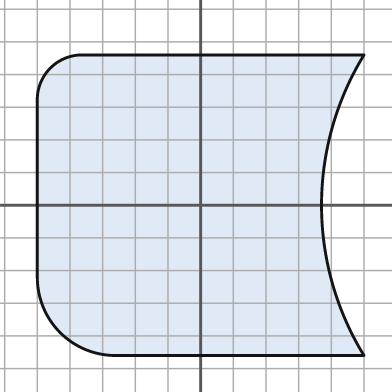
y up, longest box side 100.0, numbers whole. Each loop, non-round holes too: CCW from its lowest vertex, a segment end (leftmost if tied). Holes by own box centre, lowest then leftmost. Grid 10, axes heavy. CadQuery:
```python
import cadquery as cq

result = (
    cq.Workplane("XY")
    .moveTo(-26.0, -46.0)
    .lineTo(50.0, -46.0)
    .threePointArc((37.0, 0.0), (50.0, 46.0))
    .lineTo(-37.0, 46.0)
    .threePointArc((-46.0, 42.0), (-50.0, 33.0))
    .lineTo(-50.0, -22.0)
    .threePointArc((-43.0, -39.0), (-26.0, -46.0))
    .close()
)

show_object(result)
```